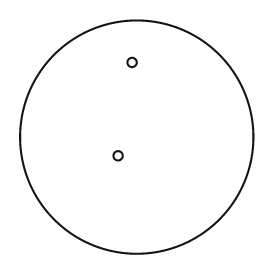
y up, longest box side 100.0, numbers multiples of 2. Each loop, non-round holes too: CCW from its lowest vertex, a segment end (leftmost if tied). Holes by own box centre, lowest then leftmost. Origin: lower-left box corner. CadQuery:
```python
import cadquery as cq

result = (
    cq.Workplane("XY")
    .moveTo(50.0, 50.0)
    .circle(50.0)
    .moveTo(42.0, 42.0)
    .circle(2.0)
    .moveTo(48.0, 82.0)
    .circle(2.0)
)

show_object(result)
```